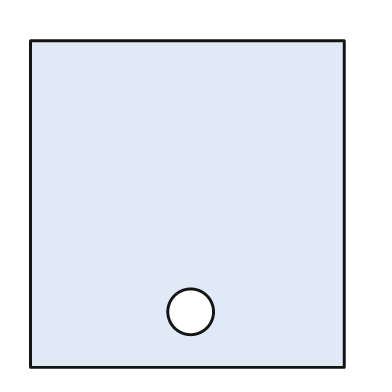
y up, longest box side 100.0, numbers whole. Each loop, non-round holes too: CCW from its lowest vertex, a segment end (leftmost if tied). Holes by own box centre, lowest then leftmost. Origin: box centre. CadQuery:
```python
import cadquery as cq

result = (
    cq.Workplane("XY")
    .moveTo(-48.0, -50.0)
    .lineTo(48.0, -50.0)
    .lineTo(48.0, 50.0)
    .lineTo(-48.0, 50.0)
    .close()
    .moveTo(1.0, -33.0)
    .circle(7.0)
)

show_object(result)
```